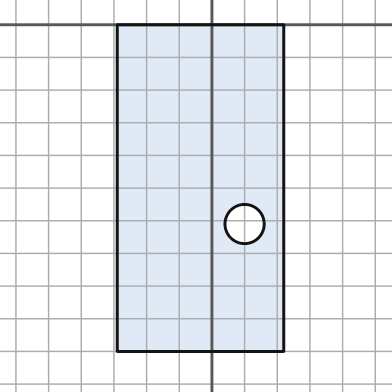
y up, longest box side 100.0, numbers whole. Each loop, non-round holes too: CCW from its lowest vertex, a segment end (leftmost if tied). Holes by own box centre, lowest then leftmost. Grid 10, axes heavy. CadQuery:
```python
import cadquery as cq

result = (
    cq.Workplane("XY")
    .moveTo(-29.0, -100.0)
    .lineTo(22.0, -100.0)
    .lineTo(22.0, 0.0)
    .lineTo(-29.0, 0.0)
    .close()
    .moveTo(10.0, -61.0)
    .circle(6.0)
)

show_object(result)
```